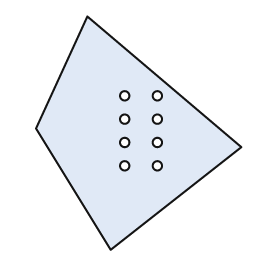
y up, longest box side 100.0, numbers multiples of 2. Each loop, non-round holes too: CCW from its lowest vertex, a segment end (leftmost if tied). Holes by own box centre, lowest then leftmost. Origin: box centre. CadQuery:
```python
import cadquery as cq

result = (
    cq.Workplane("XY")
    .moveTo(-12.0, -50.0)
    .lineTo(44.0, -6.0)
    .lineTo(-22.0, 50.0)
    .lineTo(-44.0, 2.0)
    .close()
    .moveTo(-6.0, -14.0)
    .circle(2.0)
    .moveTo(8.0, -14.0)
    .circle(2.0)
    .moveTo(-6.0, -4.0)
    .circle(2.0)
    .moveTo(8.0, -4.0)
    .circle(2.0)
    .moveTo(-6.0, 6.0)
    .circle(2.0)
    .moveTo(8.0, 6.0)
    .circle(2.0)
    .moveTo(-6.0, 16.0)
    .circle(2.0)
    .moveTo(8.0, 16.0)
    .circle(2.0)
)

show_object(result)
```